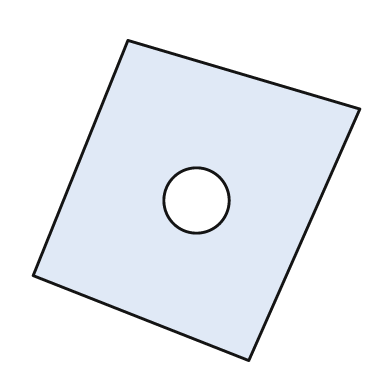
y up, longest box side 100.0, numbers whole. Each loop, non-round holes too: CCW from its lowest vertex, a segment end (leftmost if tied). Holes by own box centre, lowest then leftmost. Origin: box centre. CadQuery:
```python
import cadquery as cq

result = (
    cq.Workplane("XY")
    .moveTo(16.0, -49.0)
    .lineTo(50.0, 28.0)
    .lineTo(-21.0, 49.0)
    .lineTo(-50.0, -23.0)
    .close()
    .moveTo(0.0, 0.0)
    .circle(10.0)
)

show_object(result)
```